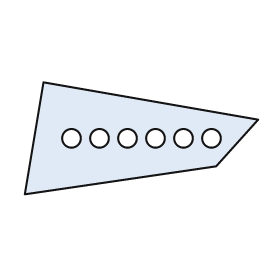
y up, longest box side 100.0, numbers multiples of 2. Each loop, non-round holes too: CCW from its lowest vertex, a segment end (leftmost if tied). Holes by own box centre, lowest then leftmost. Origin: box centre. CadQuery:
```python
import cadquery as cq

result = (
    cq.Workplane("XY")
    .moveTo(-50.0, -24.0)
    .lineTo(32.0, -12.0)
    .lineTo(50.0, 8.0)
    .lineTo(-42.0, 24.0)
    .close()
    .moveTo(-30.0, 0.0)
    .circle(4.0)
    .moveTo(-18.0, 0.0)
    .circle(4.0)
    .moveTo(-6.0, 0.0)
    .circle(4.0)
    .moveTo(6.0, 0.0)
    .circle(4.0)
    .moveTo(18.0, 0.0)
    .circle(4.0)
    .moveTo(30.0, 0.0)
    .circle(4.0)
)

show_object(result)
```